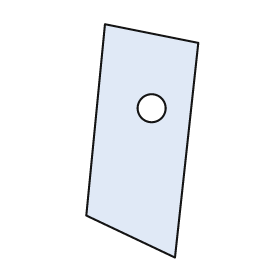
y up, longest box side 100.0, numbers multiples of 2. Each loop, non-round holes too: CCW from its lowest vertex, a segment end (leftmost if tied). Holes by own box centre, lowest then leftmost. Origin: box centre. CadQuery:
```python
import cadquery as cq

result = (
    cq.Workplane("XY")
    .moveTo(14.0, -50.0)
    .lineTo(24.0, 42.0)
    .lineTo(-16.0, 50.0)
    .lineTo(-24.0, -32.0)
    .close()
    .moveTo(4.0, 14.0)
    .circle(6.0)
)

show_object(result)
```